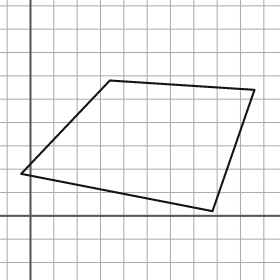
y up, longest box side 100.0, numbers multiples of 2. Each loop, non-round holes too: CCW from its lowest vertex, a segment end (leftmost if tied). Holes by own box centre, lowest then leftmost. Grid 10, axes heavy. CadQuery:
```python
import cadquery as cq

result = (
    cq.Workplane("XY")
    .moveTo(78.0, 2.0)
    .lineTo(96.0, 54.0)
    .lineTo(34.0, 58.0)
    .lineTo(-4.0, 18.0)
    .close()
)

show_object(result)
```